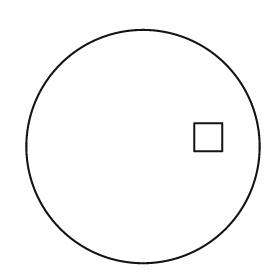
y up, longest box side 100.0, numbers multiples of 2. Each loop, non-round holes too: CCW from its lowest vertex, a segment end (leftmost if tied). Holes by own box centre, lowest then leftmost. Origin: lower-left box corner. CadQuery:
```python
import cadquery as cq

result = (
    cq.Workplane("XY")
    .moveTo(50.0, 50.0)
    .circle(50.0)
    .moveTo(72.0, 48.0)
    .lineTo(84.0, 48.0)
    .lineTo(84.0, 60.0)
    .lineTo(72.0, 60.0)
    .close()
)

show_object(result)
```